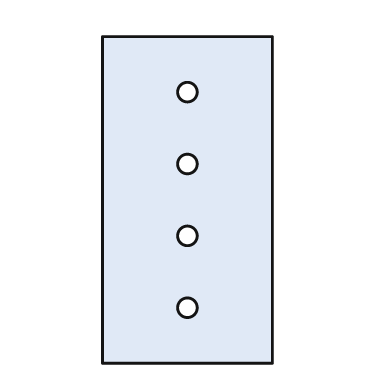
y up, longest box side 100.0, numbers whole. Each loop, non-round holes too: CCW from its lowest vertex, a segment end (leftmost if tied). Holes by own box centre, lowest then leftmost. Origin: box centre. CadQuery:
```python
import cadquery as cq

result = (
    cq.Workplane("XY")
    .moveTo(-26.0, -50.0)
    .lineTo(26.0, -50.0)
    .lineTo(26.0, 50.0)
    .lineTo(-26.0, 50.0)
    .close()
    .moveTo(0.0, -33.0)
    .circle(3.0)
    .moveTo(0.0, -11.0)
    .circle(3.0)
    .moveTo(0.0, 11.0)
    .circle(3.0)
    .moveTo(0.0, 33.0)
    .circle(3.0)
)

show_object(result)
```